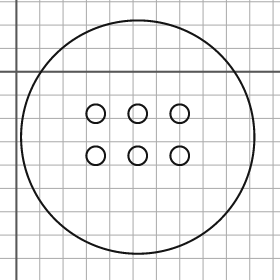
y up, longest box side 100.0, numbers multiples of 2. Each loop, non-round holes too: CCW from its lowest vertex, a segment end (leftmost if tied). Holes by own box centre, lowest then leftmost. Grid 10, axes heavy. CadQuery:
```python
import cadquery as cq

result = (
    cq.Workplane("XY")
    .moveTo(52.0, -28.0)
    .circle(50.0)
    .moveTo(34.0, -36.0)
    .circle(4.0)
    .moveTo(52.0, -36.0)
    .circle(4.0)
    .moveTo(70.0, -36.0)
    .circle(4.0)
    .moveTo(34.0, -18.0)
    .circle(4.0)
    .moveTo(52.0, -18.0)
    .circle(4.0)
    .moveTo(70.0, -18.0)
    .circle(4.0)
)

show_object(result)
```